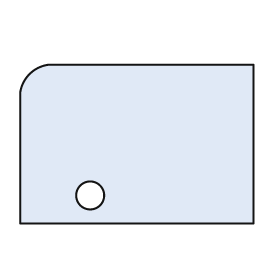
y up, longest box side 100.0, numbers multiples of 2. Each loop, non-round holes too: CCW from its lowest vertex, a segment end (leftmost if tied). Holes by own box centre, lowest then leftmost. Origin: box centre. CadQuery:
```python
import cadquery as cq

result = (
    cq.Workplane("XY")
    .moveTo(-50.0, -34.0)
    .lineTo(50.0, -34.0)
    .lineTo(50.0, 34.0)
    .lineTo(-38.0, 34.0)
    .threePointArc((-46.0, 30.0), (-50.0, 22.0))
    .close()
    .moveTo(-20.0, -22.0)
    .circle(6.0)
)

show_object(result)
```